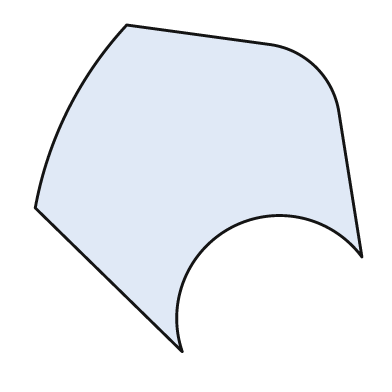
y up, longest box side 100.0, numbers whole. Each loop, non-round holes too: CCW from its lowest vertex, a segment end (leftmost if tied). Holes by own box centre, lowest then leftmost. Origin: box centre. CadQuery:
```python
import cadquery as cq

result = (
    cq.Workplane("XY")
    .moveTo(-5.0, -50.0)
    .threePointArc((10.0, -12.0), (50.0, -21.0))
    .lineTo(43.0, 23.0)
    .threePointArc((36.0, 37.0), (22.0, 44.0))
    .lineTo(-22.0, 50.0)
    .threePointArc((-40.0, 24.0), (-50.0, -6.0))
    .close()
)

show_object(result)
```